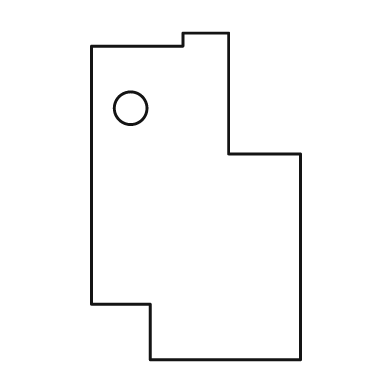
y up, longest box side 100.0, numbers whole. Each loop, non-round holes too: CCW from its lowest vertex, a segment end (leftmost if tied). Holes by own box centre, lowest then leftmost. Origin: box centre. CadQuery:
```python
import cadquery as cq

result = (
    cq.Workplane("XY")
    .moveTo(-14.0, -50.0)
    .lineTo(32.0, -50.0)
    .lineTo(32.0, 13.0)
    .lineTo(10.0, 13.0)
    .lineTo(10.0, 50.0)
    .lineTo(-4.0, 50.0)
    .lineTo(-4.0, 46.0)
    .lineTo(-32.0, 46.0)
    .lineTo(-32.0, -33.0)
    .lineTo(-14.0, -33.0)
    .close()
    .moveTo(-20.0, 27.0)
    .circle(5.0)
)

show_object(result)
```